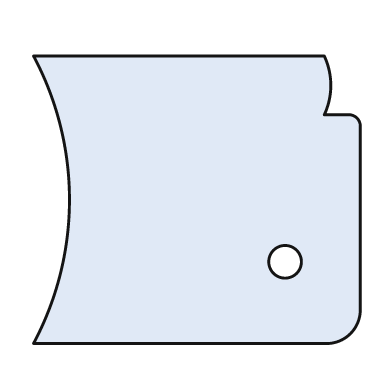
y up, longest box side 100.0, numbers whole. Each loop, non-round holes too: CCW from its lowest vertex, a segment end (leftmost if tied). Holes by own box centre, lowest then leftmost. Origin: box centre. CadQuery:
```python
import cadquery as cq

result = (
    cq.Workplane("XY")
    .moveTo(-50.0, -44.0)
    .lineTo(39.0, -44.0)
    .threePointArc((47.0, -41.0), (50.0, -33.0))
    .lineTo(50.0, 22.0)
    .threePointArc((49.0, 25.0), (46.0, 26.0))
    .lineTo(39.0, 26.0)
    .threePointArc((41.0, 35.0), (39.0, 44.0))
    .lineTo(-50.0, 44.0)
    .threePointArc((-39.0, 0.0), (-50.0, -44.0))
    .close()
    .moveTo(27.0, -19.0)
    .circle(5.0)
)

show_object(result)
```